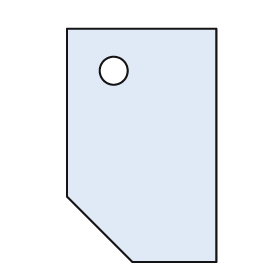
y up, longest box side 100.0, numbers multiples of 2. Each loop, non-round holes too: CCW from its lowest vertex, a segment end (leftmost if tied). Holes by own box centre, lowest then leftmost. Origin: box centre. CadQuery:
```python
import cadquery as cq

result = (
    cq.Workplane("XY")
    .moveTo(-4.0, -50.0)
    .lineTo(32.0, -50.0)
    .lineTo(32.0, 50.0)
    .lineTo(-32.0, 50.0)
    .lineTo(-32.0, -22.0)
    .close()
    .moveTo(-12.0, 32.0)
    .circle(6.0)
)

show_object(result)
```